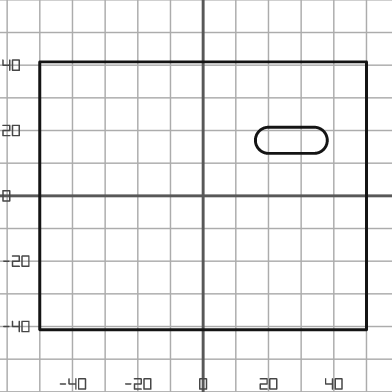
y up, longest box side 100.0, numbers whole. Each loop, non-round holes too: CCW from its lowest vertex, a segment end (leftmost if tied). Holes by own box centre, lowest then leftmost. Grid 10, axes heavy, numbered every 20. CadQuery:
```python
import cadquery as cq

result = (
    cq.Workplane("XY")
    .moveTo(-50.0, -41.0)
    .lineTo(50.0, -41.0)
    .lineTo(50.0, 41.0)
    .lineTo(-50.0, 41.0)
    .close()
    .moveTo(20.0, 13.0)
    .lineTo(34.0, 13.0)
    .threePointArc((38.0, 17.0), (34.0, 21.0))
    .lineTo(20.0, 21.0)
    .threePointArc((16.0, 17.0), (20.0, 13.0))
    .close()
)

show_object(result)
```